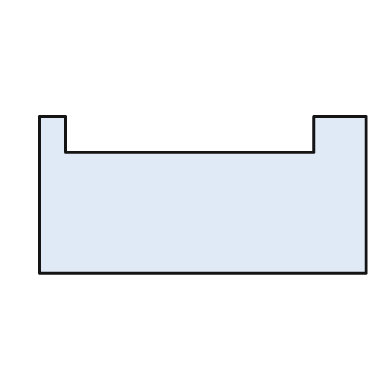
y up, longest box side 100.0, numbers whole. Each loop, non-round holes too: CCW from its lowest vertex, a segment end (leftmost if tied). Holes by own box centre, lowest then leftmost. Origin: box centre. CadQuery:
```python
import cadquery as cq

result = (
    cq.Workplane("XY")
    .moveTo(-50.0, -24.0)
    .lineTo(50.0, -24.0)
    .lineTo(50.0, 24.0)
    .lineTo(34.0, 24.0)
    .lineTo(34.0, 13.0)
    .lineTo(-42.0, 13.0)
    .lineTo(-42.0, 24.0)
    .lineTo(-50.0, 24.0)
    .close()
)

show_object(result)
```